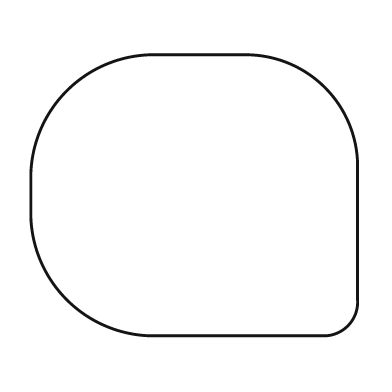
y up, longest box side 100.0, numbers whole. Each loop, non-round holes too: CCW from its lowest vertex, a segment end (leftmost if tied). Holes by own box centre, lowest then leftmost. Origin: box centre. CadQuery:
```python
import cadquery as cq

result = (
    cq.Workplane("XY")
    .moveTo(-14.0, -43.0)
    .lineTo(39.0, -43.0)
    .threePointArc((47.0, -40.0), (50.0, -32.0))
    .lineTo(50.0, 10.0)
    .threePointArc((40.0, 33.0), (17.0, 43.0))
    .lineTo(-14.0, 43.0)
    .threePointArc((-39.0, 32.0), (-50.0, 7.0))
    .lineTo(-50.0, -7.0)
    .threePointArc((-39.0, -32.0), (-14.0, -43.0))
    .close()
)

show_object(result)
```